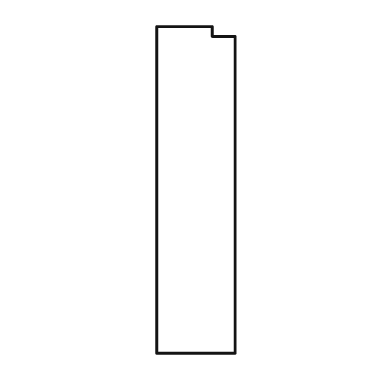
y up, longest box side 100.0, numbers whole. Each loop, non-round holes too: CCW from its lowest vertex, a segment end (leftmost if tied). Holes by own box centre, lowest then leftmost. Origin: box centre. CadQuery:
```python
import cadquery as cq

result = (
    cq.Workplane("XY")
    .moveTo(-12.0, -50.0)
    .lineTo(12.0, -50.0)
    .lineTo(12.0, 47.0)
    .lineTo(5.0, 47.0)
    .lineTo(5.0, 50.0)
    .lineTo(-12.0, 50.0)
    .close()
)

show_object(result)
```